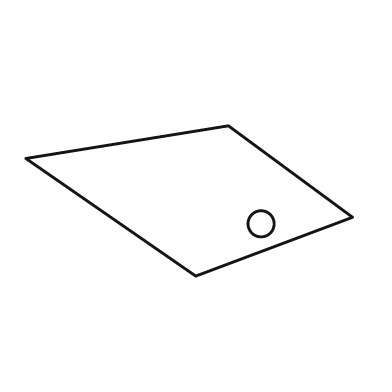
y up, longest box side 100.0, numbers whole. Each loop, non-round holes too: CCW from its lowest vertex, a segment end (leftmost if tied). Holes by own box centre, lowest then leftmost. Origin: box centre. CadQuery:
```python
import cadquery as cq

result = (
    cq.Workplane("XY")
    .moveTo(2.0, -23.0)
    .lineTo(50.0, -5.0)
    .lineTo(12.0, 23.0)
    .lineTo(-50.0, 13.0)
    .close()
    .moveTo(22.0, -7.0)
    .circle(4.0)
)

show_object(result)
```